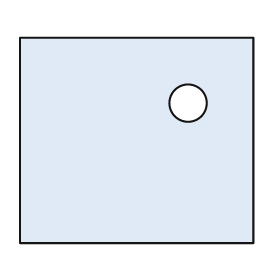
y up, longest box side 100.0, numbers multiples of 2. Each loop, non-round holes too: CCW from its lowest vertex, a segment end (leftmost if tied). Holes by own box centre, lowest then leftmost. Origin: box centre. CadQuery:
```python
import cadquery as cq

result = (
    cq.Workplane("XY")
    .moveTo(-50.0, -44.0)
    .lineTo(50.0, -44.0)
    .lineTo(50.0, 44.0)
    .lineTo(-50.0, 44.0)
    .close()
    .moveTo(22.0, 16.0)
    .circle(8.0)
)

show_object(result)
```